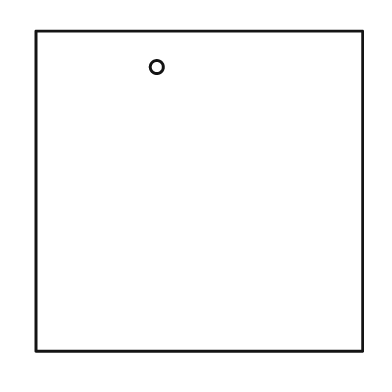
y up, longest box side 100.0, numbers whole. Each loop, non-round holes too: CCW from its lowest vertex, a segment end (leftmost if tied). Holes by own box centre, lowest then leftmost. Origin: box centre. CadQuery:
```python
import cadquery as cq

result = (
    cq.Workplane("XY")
    .moveTo(-50.0, -49.0)
    .lineTo(50.0, -49.0)
    .lineTo(50.0, 49.0)
    .lineTo(-50.0, 49.0)
    .close()
    .moveTo(-13.0, 38.0)
    .circle(2.0)
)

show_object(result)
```